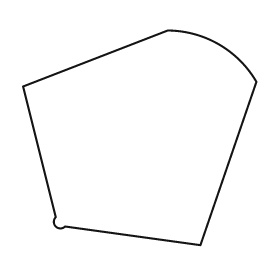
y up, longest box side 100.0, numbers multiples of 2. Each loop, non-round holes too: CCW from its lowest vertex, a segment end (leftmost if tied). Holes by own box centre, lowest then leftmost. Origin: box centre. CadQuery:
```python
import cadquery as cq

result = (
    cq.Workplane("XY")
    .moveTo(26.0, -46.0)
    .lineTo(50.0, 24.0)
    .threePointArc((34.0, 40.0), (12.0, 46.0))
    .lineTo(-50.0, 22.0)
    .lineTo(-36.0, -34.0)
    .threePointArc((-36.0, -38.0), (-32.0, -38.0))
    .close()
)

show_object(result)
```